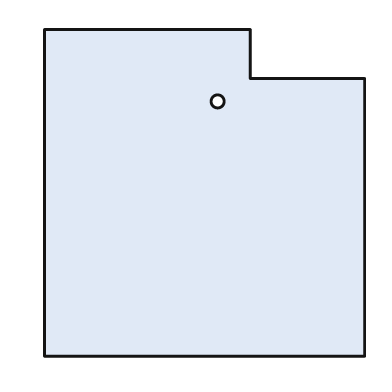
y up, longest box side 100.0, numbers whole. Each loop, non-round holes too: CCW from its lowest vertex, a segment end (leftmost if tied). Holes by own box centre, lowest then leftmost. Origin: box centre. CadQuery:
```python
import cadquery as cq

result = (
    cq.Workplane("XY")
    .moveTo(-49.0, -50.0)
    .lineTo(49.0, -50.0)
    .lineTo(49.0, 35.0)
    .lineTo(14.0, 35.0)
    .lineTo(14.0, 50.0)
    .lineTo(-49.0, 50.0)
    .close()
    .moveTo(4.0, 28.0)
    .circle(2.0)
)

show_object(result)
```